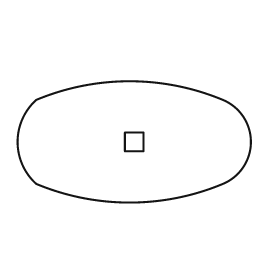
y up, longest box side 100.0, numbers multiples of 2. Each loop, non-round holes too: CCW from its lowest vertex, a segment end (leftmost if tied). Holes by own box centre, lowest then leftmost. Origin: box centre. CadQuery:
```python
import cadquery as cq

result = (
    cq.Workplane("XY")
    .moveTo(-42.0, -18.0)
    .threePointArc((-2.0, -26.0), (38.0, -18.0))
    .threePointArc((50.0, 0.0), (38.0, 18.0))
    .threePointArc((-2.0, 26.0), (-42.0, 18.0))
    .threePointArc((-50.0, 0.0), (-42.0, -18.0))
    .close()
    .moveTo(-4.0, -4.0)
    .lineTo(4.0, -4.0)
    .lineTo(4.0, 4.0)
    .lineTo(-4.0, 4.0)
    .close()
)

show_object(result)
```